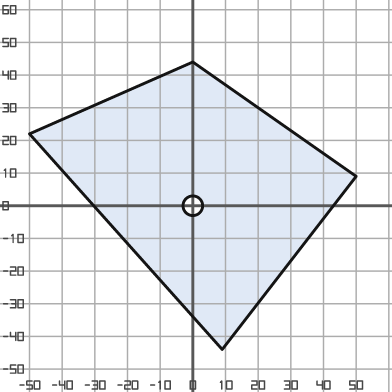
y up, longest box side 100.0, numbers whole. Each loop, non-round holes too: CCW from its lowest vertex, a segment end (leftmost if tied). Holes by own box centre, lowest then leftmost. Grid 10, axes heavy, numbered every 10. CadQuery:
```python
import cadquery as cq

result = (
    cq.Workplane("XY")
    .moveTo(9.0, -44.0)
    .lineTo(50.0, 9.0)
    .lineTo(0.0, 44.0)
    .lineTo(-50.0, 22.0)
    .close()
    .moveTo(0.0, 0.0)
    .circle(3.0)
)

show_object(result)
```